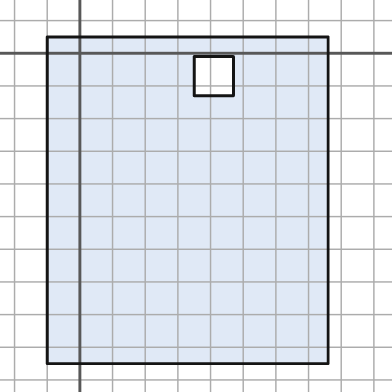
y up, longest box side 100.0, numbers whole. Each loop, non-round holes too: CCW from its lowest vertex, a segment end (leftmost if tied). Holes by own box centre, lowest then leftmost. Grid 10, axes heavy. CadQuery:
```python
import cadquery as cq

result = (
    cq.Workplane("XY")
    .moveTo(-10.0, -95.0)
    .lineTo(76.0, -95.0)
    .lineTo(76.0, 5.0)
    .lineTo(-10.0, 5.0)
    .close()
    .moveTo(35.0, -13.0)
    .lineTo(47.0, -13.0)
    .lineTo(47.0, -1.0)
    .lineTo(35.0, -1.0)
    .close()
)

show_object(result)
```